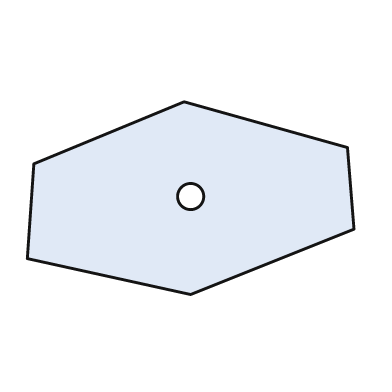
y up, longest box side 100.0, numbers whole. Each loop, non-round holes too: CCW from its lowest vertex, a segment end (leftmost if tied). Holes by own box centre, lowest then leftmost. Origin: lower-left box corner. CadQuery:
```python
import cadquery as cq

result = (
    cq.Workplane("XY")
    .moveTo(50.0, 0.0)
    .lineTo(100.0, 20.0)
    .lineTo(98.0, 45.0)
    .lineTo(48.0, 59.0)
    .lineTo(2.0, 40.0)
    .lineTo(0.0, 11.0)
    .close()
    .moveTo(50.0, 30.0)
    .circle(4.0)
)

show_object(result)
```